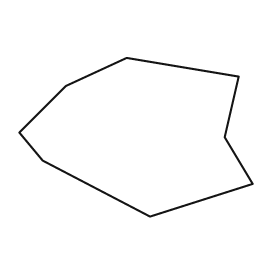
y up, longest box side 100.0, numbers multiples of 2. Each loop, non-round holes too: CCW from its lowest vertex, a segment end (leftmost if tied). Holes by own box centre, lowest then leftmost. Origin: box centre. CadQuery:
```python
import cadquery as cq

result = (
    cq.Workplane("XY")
    .moveTo(6.0, -34.0)
    .lineTo(50.0, -20.0)
    .lineTo(38.0, 0.0)
    .lineTo(44.0, 26.0)
    .lineTo(-4.0, 34.0)
    .lineTo(-30.0, 22.0)
    .lineTo(-50.0, 2.0)
    .lineTo(-40.0, -10.0)
    .close()
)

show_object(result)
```